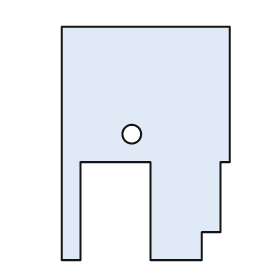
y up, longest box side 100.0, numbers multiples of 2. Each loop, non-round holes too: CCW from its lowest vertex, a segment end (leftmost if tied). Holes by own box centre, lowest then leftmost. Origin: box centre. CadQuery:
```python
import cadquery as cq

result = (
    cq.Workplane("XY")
    .moveTo(-36.0, -50.0)
    .lineTo(-28.0, -50.0)
    .lineTo(-28.0, -8.0)
    .lineTo(2.0, -8.0)
    .lineTo(2.0, -50.0)
    .lineTo(24.0, -50.0)
    .lineTo(24.0, -38.0)
    .lineTo(32.0, -38.0)
    .lineTo(32.0, -8.0)
    .lineTo(36.0, -8.0)
    .lineTo(36.0, 50.0)
    .lineTo(-36.0, 50.0)
    .close()
    .moveTo(-6.0, 4.0)
    .circle(4.0)
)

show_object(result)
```